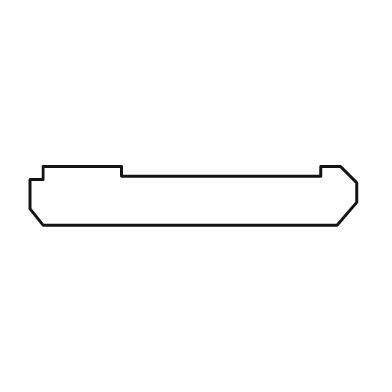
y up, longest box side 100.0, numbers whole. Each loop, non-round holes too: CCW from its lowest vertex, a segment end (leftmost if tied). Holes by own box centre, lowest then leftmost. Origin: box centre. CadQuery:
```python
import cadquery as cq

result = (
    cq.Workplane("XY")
    .moveTo(-46.0, -9.0)
    .lineTo(44.0, -9.0)
    .lineTo(50.0, -2.0)
    .lineTo(50.0, 4.0)
    .lineTo(45.0, 9.0)
    .lineTo(39.0, 9.0)
    .lineTo(39.0, 6.0)
    .lineTo(-22.0, 6.0)
    .lineTo(-22.0, 9.0)
    .lineTo(-46.0, 9.0)
    .lineTo(-46.0, 5.0)
    .lineTo(-50.0, 5.0)
    .lineTo(-50.0, -4.0)
    .close()
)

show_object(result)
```